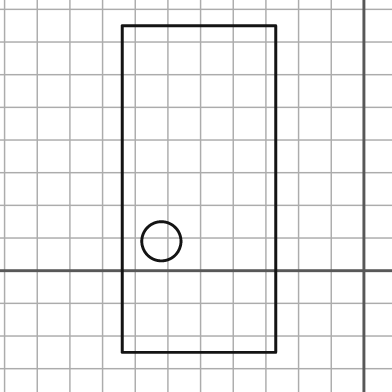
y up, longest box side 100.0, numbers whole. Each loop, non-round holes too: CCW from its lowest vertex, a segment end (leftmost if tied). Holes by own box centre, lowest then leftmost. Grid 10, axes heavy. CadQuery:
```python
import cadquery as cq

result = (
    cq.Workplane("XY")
    .moveTo(-74.0, -25.0)
    .lineTo(-27.0, -25.0)
    .lineTo(-27.0, 75.0)
    .lineTo(-74.0, 75.0)
    .close()
    .moveTo(-62.0, 9.0)
    .circle(6.0)
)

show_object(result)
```